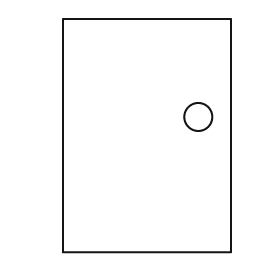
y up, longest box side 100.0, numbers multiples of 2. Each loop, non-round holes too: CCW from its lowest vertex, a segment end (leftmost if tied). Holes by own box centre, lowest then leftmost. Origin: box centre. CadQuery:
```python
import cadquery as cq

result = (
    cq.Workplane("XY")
    .moveTo(-36.0, -50.0)
    .lineTo(36.0, -50.0)
    .lineTo(36.0, 50.0)
    .lineTo(-36.0, 50.0)
    .close()
    .moveTo(22.0, 8.0)
    .circle(6.0)
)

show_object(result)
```